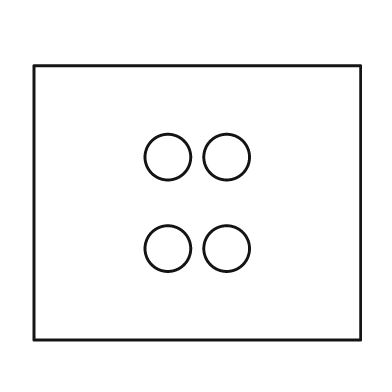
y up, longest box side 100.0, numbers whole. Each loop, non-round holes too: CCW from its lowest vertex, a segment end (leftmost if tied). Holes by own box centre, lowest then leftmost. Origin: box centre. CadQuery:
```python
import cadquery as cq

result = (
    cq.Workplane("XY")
    .moveTo(-50.0, -42.0)
    .lineTo(50.0, -42.0)
    .lineTo(50.0, 42.0)
    .lineTo(-50.0, 42.0)
    .close()
    .moveTo(-9.0, -14.0)
    .circle(7.0)
    .moveTo(9.0, -14.0)
    .circle(7.0)
    .moveTo(-9.0, 14.0)
    .circle(7.0)
    .moveTo(9.0, 14.0)
    .circle(7.0)
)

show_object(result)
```